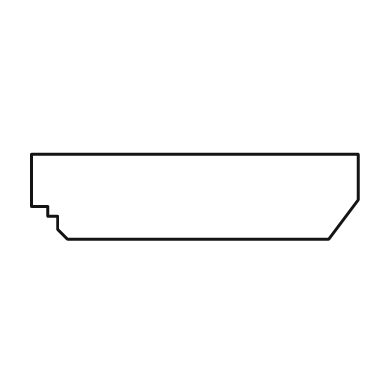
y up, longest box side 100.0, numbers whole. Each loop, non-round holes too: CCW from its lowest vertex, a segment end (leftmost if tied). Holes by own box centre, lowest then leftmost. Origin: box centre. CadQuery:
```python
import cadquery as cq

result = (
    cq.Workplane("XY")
    .moveTo(-39.0, -13.0)
    .lineTo(41.0, -13.0)
    .lineTo(50.0, -1.0)
    .lineTo(50.0, 13.0)
    .lineTo(-50.0, 13.0)
    .lineTo(-50.0, -3.0)
    .lineTo(-45.0, -3.0)
    .lineTo(-45.0, -6.0)
    .lineTo(-42.0, -6.0)
    .lineTo(-42.0, -10.0)
    .close()
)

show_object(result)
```